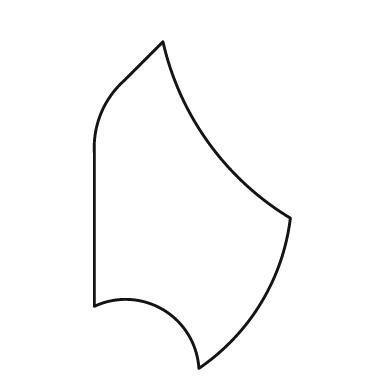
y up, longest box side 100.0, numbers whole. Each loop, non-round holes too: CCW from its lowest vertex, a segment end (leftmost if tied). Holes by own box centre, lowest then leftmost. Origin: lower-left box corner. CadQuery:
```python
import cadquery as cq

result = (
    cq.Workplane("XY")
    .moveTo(32.0, 0.0)
    .threePointArc((51.0, 20.0), (60.0, 46.0))
    .threePointArc((35.0, 69.0), (21.0, 100.0))
    .lineTo(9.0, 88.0)
    .threePointArc((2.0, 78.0), (0.0, 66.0))
    .lineTo(0.0, 19.0)
    .threePointArc((21.0, 18.0), (32.0, 0.0))
    .close()
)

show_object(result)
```